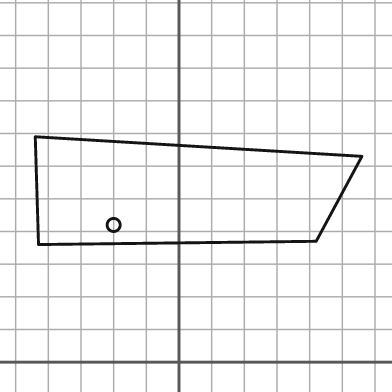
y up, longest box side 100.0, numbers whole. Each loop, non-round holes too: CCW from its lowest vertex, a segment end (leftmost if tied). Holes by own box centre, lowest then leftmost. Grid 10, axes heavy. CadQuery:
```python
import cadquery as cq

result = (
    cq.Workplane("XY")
    .moveTo(-43.0, 36.0)
    .lineTo(42.0, 37.0)
    .lineTo(56.0, 63.0)
    .lineTo(-44.0, 69.0)
    .close()
    .moveTo(-20.0, 42.0)
    .circle(2.0)
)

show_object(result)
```